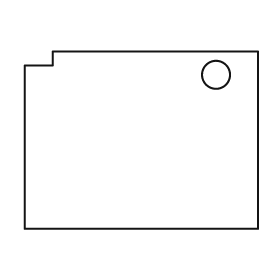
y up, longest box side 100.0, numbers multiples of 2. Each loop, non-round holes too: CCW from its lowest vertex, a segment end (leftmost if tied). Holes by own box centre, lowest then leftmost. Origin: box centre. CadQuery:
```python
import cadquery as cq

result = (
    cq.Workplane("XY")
    .moveTo(-50.0, -38.0)
    .lineTo(50.0, -38.0)
    .lineTo(50.0, 38.0)
    .lineTo(-38.0, 38.0)
    .lineTo(-38.0, 32.0)
    .lineTo(-50.0, 32.0)
    .close()
    .moveTo(32.0, 28.0)
    .circle(6.0)
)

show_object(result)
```